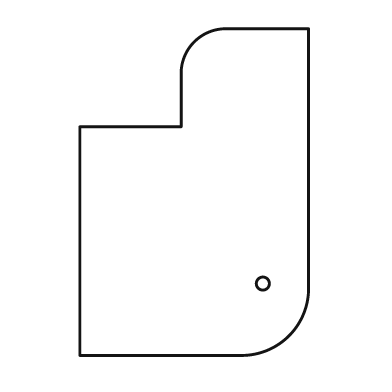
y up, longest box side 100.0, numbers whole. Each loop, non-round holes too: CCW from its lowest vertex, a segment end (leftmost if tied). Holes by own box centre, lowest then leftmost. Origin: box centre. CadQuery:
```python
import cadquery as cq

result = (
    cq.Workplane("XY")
    .moveTo(-35.0, -50.0)
    .lineTo(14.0, -50.0)
    .threePointArc((29.0, -44.0), (35.0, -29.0))
    .lineTo(35.0, 50.0)
    .lineTo(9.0, 50.0)
    .threePointArc((0.0, 46.0), (-4.0, 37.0))
    .lineTo(-4.0, 20.0)
    .lineTo(-35.0, 20.0)
    .close()
    .moveTo(21.0, -28.0)
    .circle(2.0)
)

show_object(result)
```